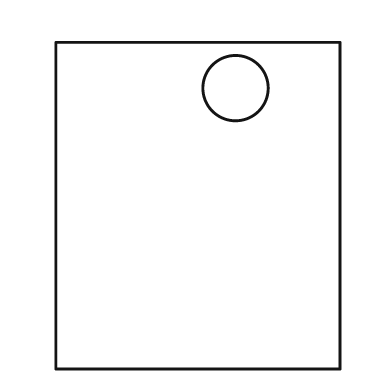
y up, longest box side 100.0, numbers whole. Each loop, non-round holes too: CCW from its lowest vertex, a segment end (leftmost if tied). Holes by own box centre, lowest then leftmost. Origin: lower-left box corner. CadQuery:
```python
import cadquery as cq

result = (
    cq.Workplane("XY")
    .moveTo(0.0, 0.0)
    .lineTo(87.0, 0.0)
    .lineTo(87.0, 100.0)
    .lineTo(0.0, 100.0)
    .close()
    .moveTo(55.0, 86.0)
    .circle(10.0)
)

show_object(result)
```